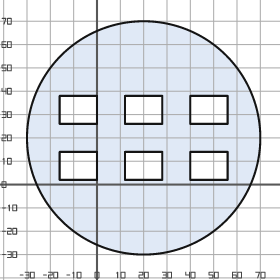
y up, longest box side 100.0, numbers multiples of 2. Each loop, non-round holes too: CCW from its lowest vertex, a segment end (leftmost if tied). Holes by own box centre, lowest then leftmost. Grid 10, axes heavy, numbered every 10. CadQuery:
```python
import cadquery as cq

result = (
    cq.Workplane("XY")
    .moveTo(20.0, 20.0)
    .circle(50.0)
    .moveTo(-16.0, 2.0)
    .lineTo(0.0, 2.0)
    .lineTo(0.0, 14.0)
    .lineTo(-16.0, 14.0)
    .close()
    .moveTo(12.0, 2.0)
    .lineTo(28.0, 2.0)
    .lineTo(28.0, 14.0)
    .lineTo(12.0, 14.0)
    .close()
    .moveTo(40.0, 2.0)
    .lineTo(56.0, 2.0)
    .lineTo(56.0, 14.0)
    .lineTo(40.0, 14.0)
    .close()
    .moveTo(-16.0, 26.0)
    .lineTo(0.0, 26.0)
    .lineTo(0.0, 38.0)
    .lineTo(-16.0, 38.0)
    .close()
    .moveTo(12.0, 26.0)
    .lineTo(28.0, 26.0)
    .lineTo(28.0, 38.0)
    .lineTo(12.0, 38.0)
    .close()
    .moveTo(40.0, 26.0)
    .lineTo(56.0, 26.0)
    .lineTo(56.0, 38.0)
    .lineTo(40.0, 38.0)
    .close()
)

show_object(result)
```